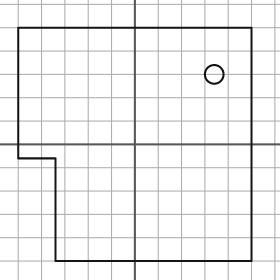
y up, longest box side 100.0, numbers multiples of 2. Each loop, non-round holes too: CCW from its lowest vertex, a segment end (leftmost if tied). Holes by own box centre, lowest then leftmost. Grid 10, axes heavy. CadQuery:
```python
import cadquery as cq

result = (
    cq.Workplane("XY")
    .moveTo(-34.0, -50.0)
    .lineTo(50.0, -50.0)
    .lineTo(50.0, 50.0)
    .lineTo(-50.0, 50.0)
    .lineTo(-50.0, -6.0)
    .lineTo(-34.0, -6.0)
    .close()
    .moveTo(34.0, 30.0)
    .circle(4.0)
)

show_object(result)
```